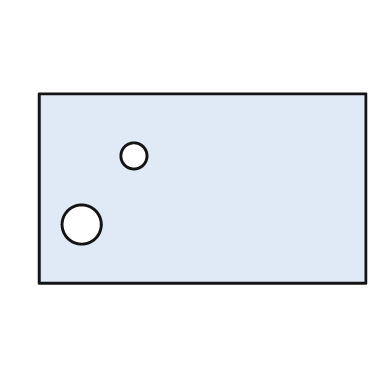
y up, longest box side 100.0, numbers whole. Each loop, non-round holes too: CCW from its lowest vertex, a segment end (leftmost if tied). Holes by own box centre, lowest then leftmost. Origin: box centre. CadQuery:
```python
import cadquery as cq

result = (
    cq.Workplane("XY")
    .moveTo(-50.0, -29.0)
    .lineTo(50.0, -29.0)
    .lineTo(50.0, 29.0)
    .lineTo(-50.0, 29.0)
    .close()
    .moveTo(-37.0, -11.0)
    .circle(6.0)
    .moveTo(-21.0, 10.0)
    .circle(4.0)
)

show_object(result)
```